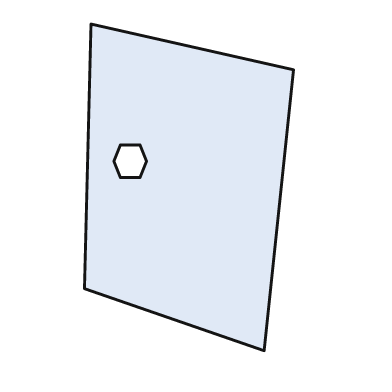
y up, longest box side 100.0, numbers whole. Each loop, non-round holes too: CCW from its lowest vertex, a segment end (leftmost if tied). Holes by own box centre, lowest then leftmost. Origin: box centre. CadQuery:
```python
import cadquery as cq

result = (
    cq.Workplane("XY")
    .moveTo(23.0, -50.0)
    .lineTo(32.0, 36.0)
    .lineTo(-30.0, 50.0)
    .lineTo(-32.0, -31.0)
    .close()
    .moveTo(-21.0, 3.0)
    .lineTo(-15.0, 3.0)
    .lineTo(-13.0, 8.0)
    .lineTo(-15.0, 13.0)
    .lineTo(-21.0, 13.0)
    .lineTo(-23.0, 8.0)
    .close()
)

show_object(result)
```